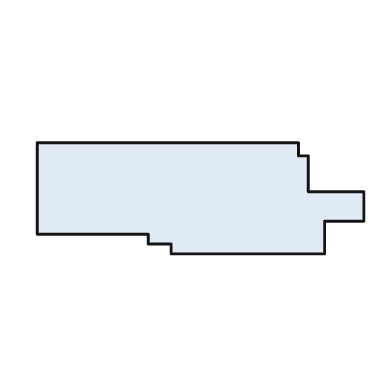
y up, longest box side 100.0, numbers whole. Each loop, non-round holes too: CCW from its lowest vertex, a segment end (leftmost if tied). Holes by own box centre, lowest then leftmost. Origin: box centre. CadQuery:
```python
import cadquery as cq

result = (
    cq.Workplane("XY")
    .moveTo(-9.0, -17.0)
    .lineTo(38.0, -17.0)
    .lineTo(38.0, -7.0)
    .lineTo(50.0, -7.0)
    .lineTo(50.0, 2.0)
    .lineTo(33.0, 2.0)
    .lineTo(33.0, 13.0)
    .lineTo(30.0, 13.0)
    .lineTo(30.0, 17.0)
    .lineTo(-50.0, 17.0)
    .lineTo(-50.0, -11.0)
    .lineTo(-16.0, -11.0)
    .lineTo(-16.0, -14.0)
    .lineTo(-9.0, -14.0)
    .close()
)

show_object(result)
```